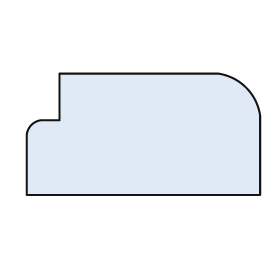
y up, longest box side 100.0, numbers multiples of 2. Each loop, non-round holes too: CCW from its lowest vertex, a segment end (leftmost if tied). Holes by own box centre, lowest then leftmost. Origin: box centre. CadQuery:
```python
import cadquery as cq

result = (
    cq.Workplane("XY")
    .moveTo(-50.0, -26.0)
    .lineTo(50.0, -26.0)
    .lineTo(50.0, 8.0)
    .threePointArc((44.0, 20.0), (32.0, 26.0))
    .lineTo(-36.0, 26.0)
    .lineTo(-36.0, 6.0)
    .lineTo(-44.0, 6.0)
    .threePointArc((-48.0, 4.0), (-50.0, 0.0))
    .close()
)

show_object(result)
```